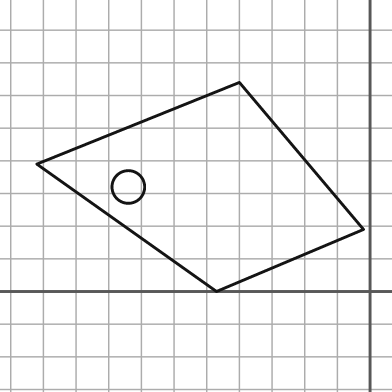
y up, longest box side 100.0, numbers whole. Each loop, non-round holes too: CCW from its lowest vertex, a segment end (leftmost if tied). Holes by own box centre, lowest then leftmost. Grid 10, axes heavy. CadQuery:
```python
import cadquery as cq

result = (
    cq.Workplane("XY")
    .moveTo(-47.0, 0.0)
    .lineTo(-2.0, 19.0)
    .lineTo(-40.0, 64.0)
    .lineTo(-102.0, 39.0)
    .close()
    .moveTo(-74.0, 32.0)
    .circle(5.0)
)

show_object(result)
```